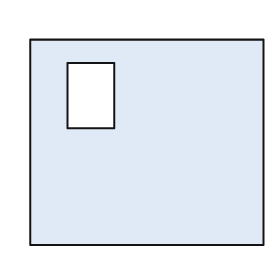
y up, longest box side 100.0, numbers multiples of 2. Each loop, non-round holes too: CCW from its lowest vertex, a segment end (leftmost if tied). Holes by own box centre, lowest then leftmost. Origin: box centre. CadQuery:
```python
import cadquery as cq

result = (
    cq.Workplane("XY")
    .moveTo(-50.0, -44.0)
    .lineTo(50.0, -44.0)
    .lineTo(50.0, 44.0)
    .lineTo(-50.0, 44.0)
    .close()
    .moveTo(-34.0, 6.0)
    .lineTo(-14.0, 6.0)
    .lineTo(-14.0, 34.0)
    .lineTo(-34.0, 34.0)
    .close()
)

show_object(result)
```